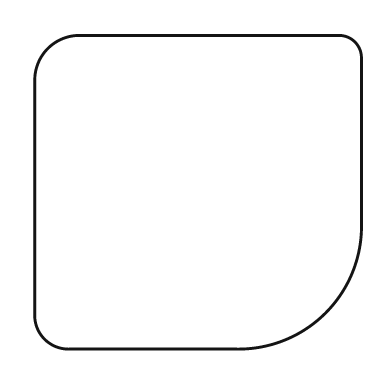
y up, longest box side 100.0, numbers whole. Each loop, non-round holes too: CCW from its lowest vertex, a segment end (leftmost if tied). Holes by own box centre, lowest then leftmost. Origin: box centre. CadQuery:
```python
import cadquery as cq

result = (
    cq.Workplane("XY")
    .moveTo(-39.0, -48.0)
    .lineTo(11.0, -48.0)
    .threePointArc((39.0, -37.0), (50.0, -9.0))
    .lineTo(50.0, 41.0)
    .threePointArc((48.0, 46.0), (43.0, 48.0))
    .lineTo(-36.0, 48.0)
    .threePointArc((-46.0, 44.0), (-50.0, 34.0))
    .lineTo(-50.0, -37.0)
    .threePointArc((-47.0, -45.0), (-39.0, -48.0))
    .close()
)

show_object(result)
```